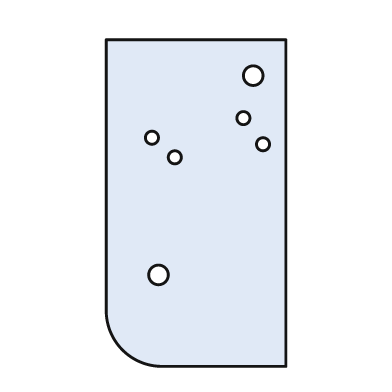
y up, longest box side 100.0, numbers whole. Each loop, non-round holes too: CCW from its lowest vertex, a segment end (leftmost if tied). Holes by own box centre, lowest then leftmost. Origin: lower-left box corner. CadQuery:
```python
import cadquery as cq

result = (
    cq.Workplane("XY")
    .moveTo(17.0, 0.0)
    .lineTo(55.0, 0.0)
    .lineTo(55.0, 100.0)
    .lineTo(0.0, 100.0)
    .lineTo(0.0, 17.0)
    .threePointArc((5.0, 5.0), (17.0, 0.0))
    .close()
    .moveTo(16.0, 28.0)
    .circle(3.0)
    .moveTo(21.0, 64.0)
    .circle(2.0)
    .moveTo(48.0, 68.0)
    .circle(2.0)
    .moveTo(14.0, 70.0)
    .circle(2.0)
    .moveTo(42.0, 76.0)
    .circle(2.0)
    .moveTo(45.0, 89.0)
    .circle(3.0)
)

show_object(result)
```